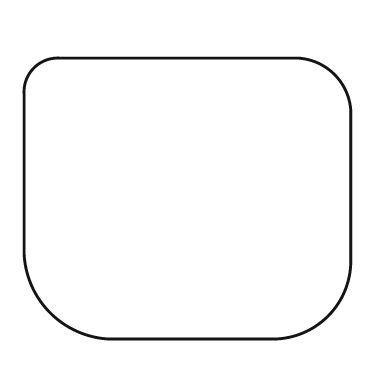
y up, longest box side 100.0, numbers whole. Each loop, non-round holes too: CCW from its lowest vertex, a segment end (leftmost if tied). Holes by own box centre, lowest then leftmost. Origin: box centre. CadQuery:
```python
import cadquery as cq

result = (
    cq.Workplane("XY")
    .moveTo(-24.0, -43.0)
    .lineTo(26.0, -43.0)
    .threePointArc((43.0, -36.0), (50.0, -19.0))
    .lineTo(50.0, 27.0)
    .threePointArc((45.0, 38.0), (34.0, 43.0))
    .lineTo(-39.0, 43.0)
    .threePointArc((-47.0, 40.0), (-50.0, 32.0))
    .lineTo(-50.0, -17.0)
    .threePointArc((-42.0, -35.0), (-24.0, -43.0))
    .close()
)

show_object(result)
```